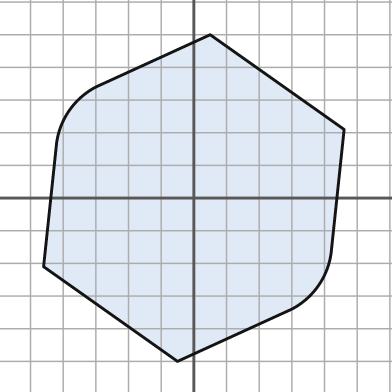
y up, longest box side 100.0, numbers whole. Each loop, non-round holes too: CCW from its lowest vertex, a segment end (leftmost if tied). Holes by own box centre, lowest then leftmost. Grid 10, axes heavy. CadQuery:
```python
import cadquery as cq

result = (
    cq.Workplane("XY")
    .moveTo(-5.0, -50.0)
    .lineTo(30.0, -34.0)
    .threePointArc((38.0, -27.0), (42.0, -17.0))
    .lineTo(46.0, 21.0)
    .lineTo(5.0, 50.0)
    .lineTo(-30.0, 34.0)
    .threePointArc((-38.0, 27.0), (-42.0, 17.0))
    .lineTo(-46.0, -21.0)
    .close()
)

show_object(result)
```